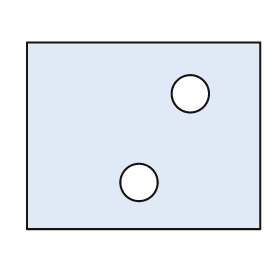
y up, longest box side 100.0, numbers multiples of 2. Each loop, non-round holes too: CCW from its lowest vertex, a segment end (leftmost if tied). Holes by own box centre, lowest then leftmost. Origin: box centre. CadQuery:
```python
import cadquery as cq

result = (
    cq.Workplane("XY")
    .moveTo(-50.0, -40.0)
    .lineTo(50.0, -40.0)
    .lineTo(50.0, 40.0)
    .lineTo(-50.0, 40.0)
    .close()
    .moveTo(-2.0, -20.0)
    .circle(8.0)
    .moveTo(20.0, 18.0)
    .circle(8.0)
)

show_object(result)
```